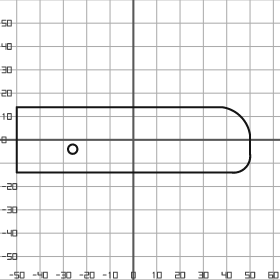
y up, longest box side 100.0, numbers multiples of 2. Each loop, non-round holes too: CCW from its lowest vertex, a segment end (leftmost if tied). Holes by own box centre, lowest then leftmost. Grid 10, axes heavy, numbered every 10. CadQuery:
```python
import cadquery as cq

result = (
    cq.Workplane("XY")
    .moveTo(-50.0, -14.0)
    .lineTo(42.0, -14.0)
    .threePointArc((48.0, -12.0), (50.0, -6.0))
    .lineTo(50.0, 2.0)
    .threePointArc((46.0, 10.0), (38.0, 14.0))
    .lineTo(-50.0, 14.0)
    .close()
    .moveTo(-26.0, -4.0)
    .circle(2.0)
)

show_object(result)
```